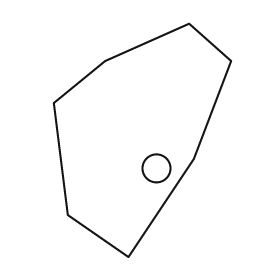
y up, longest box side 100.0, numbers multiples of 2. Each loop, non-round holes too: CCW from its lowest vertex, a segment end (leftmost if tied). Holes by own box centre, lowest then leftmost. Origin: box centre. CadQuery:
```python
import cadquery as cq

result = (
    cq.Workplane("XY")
    .moveTo(-6.0, -50.0)
    .lineTo(22.0, -8.0)
    .lineTo(38.0, 34.0)
    .lineTo(20.0, 50.0)
    .lineTo(-16.0, 34.0)
    .lineTo(-38.0, 16.0)
    .lineTo(-32.0, -32.0)
    .close()
    .moveTo(6.0, -12.0)
    .circle(6.0)
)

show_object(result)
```